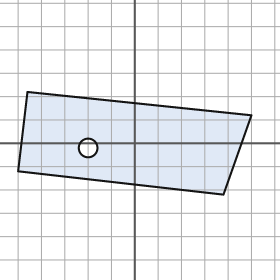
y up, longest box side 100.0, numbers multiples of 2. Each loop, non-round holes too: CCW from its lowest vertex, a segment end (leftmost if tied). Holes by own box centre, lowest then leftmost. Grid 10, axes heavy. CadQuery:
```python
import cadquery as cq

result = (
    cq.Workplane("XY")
    .moveTo(38.0, -22.0)
    .lineTo(50.0, 12.0)
    .lineTo(-46.0, 22.0)
    .lineTo(-50.0, -12.0)
    .close()
    .moveTo(-20.0, -2.0)
    .circle(4.0)
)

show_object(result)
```